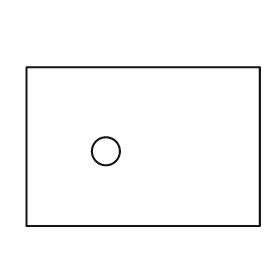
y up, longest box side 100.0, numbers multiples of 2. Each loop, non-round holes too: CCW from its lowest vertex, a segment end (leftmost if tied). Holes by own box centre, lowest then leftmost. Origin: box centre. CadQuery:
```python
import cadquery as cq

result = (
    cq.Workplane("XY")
    .moveTo(-50.0, -34.0)
    .lineTo(50.0, -34.0)
    .lineTo(50.0, 34.0)
    .lineTo(-50.0, 34.0)
    .close()
    .moveTo(-16.0, -2.0)
    .circle(6.0)
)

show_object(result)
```